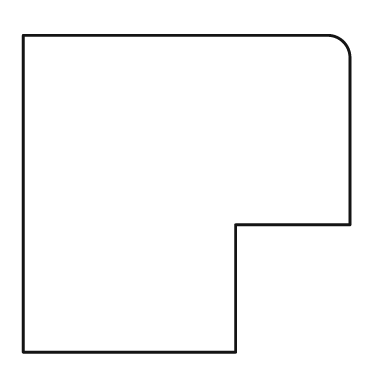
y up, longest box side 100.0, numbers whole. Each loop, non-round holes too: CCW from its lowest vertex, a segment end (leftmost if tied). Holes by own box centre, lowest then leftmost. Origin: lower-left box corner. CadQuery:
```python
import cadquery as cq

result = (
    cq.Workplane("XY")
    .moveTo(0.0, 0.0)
    .lineTo(65.0, 0.0)
    .lineTo(65.0, 39.0)
    .lineTo(100.0, 39.0)
    .lineTo(100.0, 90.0)
    .threePointArc((98.0, 95.0), (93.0, 97.0))
    .lineTo(0.0, 97.0)
    .close()
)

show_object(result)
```